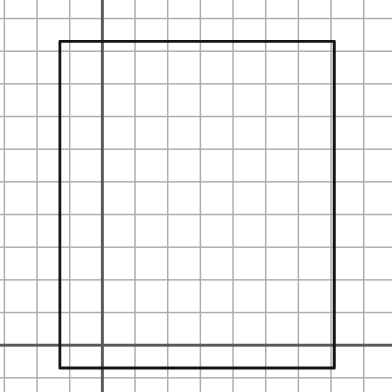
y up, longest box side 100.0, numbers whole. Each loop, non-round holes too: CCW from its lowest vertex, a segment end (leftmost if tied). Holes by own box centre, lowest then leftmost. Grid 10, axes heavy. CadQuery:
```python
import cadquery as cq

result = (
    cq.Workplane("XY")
    .moveTo(-13.0, -7.0)
    .lineTo(71.0, -7.0)
    .lineTo(71.0, 93.0)
    .lineTo(-13.0, 93.0)
    .close()
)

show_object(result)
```